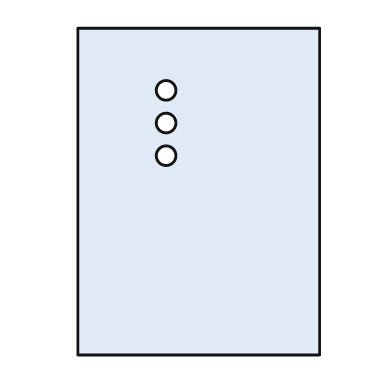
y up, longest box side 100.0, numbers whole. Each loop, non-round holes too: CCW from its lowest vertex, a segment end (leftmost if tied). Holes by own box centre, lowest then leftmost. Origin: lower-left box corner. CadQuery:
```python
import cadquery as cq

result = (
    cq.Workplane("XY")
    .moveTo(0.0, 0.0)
    .lineTo(74.0, 0.0)
    .lineTo(74.0, 100.0)
    .lineTo(0.0, 100.0)
    .close()
    .moveTo(27.0, 61.0)
    .circle(3.0)
    .moveTo(27.0, 71.0)
    .circle(3.0)
    .moveTo(27.0, 81.0)
    .circle(3.0)
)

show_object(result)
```